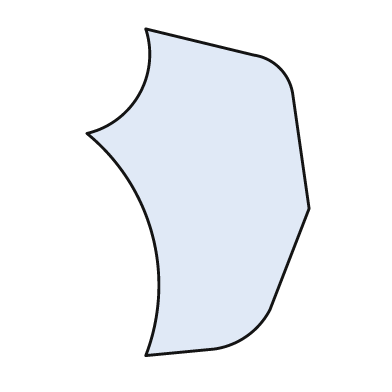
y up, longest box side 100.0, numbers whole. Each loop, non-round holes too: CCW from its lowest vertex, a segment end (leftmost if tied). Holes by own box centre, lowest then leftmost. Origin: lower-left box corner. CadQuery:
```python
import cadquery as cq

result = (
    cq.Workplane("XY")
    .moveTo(18.0, 0.0)
    .lineTo(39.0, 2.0)
    .threePointArc((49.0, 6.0), (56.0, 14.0))
    .lineTo(68.0, 45.0)
    .lineTo(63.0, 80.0)
    .threePointArc((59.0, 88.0), (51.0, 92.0))
    .lineTo(18.0, 100.0)
    .threePointArc((16.0, 80.0), (0.0, 68.0))
    .threePointArc((20.0, 37.0), (18.0, 0.0))
    .close()
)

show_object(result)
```